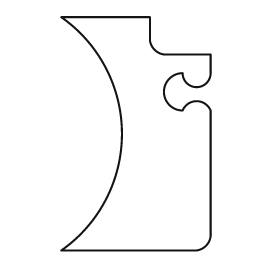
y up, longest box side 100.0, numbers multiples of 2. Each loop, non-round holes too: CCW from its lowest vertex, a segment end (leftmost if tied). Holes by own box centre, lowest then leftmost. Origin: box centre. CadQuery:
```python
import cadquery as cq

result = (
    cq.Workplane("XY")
    .moveTo(-32.0, -50.0)
    .lineTo(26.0, -50.0)
    .threePointArc((30.0, -48.0), (32.0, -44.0))
    .lineTo(32.0, 10.0)
    .threePointArc((26.0, 14.0), (20.0, 10.0))
    .threePointArc((12.0, 18.0), (20.0, 26.0))
    .threePointArc((26.0, 20.0), (32.0, 26.0))
    .lineTo(32.0, 34.0)
    .lineTo(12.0, 34.0)
    .threePointArc((8.0, 36.0), (6.0, 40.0))
    .lineTo(6.0, 50.0)
    .lineTo(-32.0, 50.0)
    .threePointArc((-6.0, 0.0), (-32.0, -50.0))
    .close()
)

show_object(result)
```